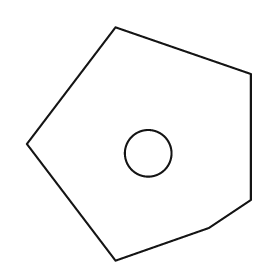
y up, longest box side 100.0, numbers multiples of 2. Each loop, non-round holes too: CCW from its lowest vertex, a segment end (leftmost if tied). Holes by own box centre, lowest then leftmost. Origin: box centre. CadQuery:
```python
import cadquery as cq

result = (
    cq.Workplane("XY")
    .moveTo(-10.0, -50.0)
    .lineTo(30.0, -36.0)
    .lineTo(48.0, -24.0)
    .lineTo(48.0, 30.0)
    .lineTo(-10.0, 50.0)
    .lineTo(-48.0, 0.0)
    .close()
    .moveTo(4.0, -4.0)
    .circle(10.0)
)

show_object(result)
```